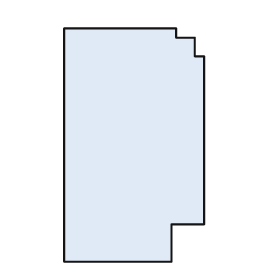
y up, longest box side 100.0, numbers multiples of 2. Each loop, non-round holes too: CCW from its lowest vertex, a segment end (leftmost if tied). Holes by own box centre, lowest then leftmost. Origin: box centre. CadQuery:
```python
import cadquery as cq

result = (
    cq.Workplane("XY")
    .moveTo(-30.0, -50.0)
    .lineTo(16.0, -50.0)
    .lineTo(16.0, -34.0)
    .lineTo(30.0, -34.0)
    .lineTo(30.0, 38.0)
    .lineTo(26.0, 38.0)
    .lineTo(26.0, 46.0)
    .lineTo(18.0, 46.0)
    .lineTo(18.0, 50.0)
    .lineTo(-30.0, 50.0)
    .close()
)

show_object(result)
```